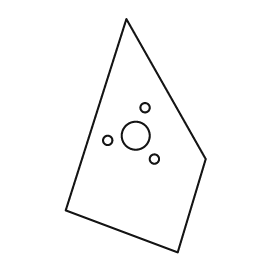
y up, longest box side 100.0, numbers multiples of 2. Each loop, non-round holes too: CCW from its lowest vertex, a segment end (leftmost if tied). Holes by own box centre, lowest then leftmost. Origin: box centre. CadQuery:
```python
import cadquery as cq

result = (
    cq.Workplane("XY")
    .moveTo(18.0, -50.0)
    .lineTo(30.0, -10.0)
    .lineTo(-4.0, 50.0)
    .lineTo(-30.0, -32.0)
    .close()
    .moveTo(8.0, -10.0)
    .circle(2.0)
    .moveTo(-12.0, -2.0)
    .circle(2.0)
    .moveTo(0.0, 0.0)
    .circle(6.0)
    .moveTo(4.0, 12.0)
    .circle(2.0)
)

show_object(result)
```